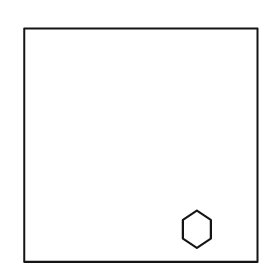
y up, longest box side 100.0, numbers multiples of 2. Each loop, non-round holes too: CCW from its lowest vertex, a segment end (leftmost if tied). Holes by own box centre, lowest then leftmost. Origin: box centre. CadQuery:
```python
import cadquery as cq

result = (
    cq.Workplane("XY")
    .moveTo(-50.0, -50.0)
    .lineTo(50.0, -50.0)
    .lineTo(50.0, 50.0)
    .lineTo(-50.0, 50.0)
    .close()
    .moveTo(24.0, -44.0)
    .lineTo(30.0, -40.0)
    .lineTo(30.0, -32.0)
    .lineTo(24.0, -28.0)
    .lineTo(18.0, -32.0)
    .lineTo(18.0, -40.0)
    .close()
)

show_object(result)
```